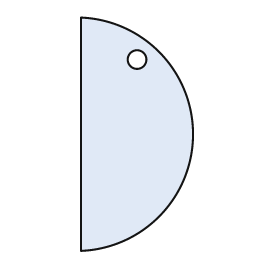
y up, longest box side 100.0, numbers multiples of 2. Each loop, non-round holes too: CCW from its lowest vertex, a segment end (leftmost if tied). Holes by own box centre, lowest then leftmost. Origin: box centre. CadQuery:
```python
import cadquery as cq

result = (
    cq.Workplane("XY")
    .moveTo(-24.0, -50.0)
    .threePointArc((24.0, 0.0), (-24.0, 50.0))
    .close()
    .moveTo(0.0, 32.0)
    .circle(4.0)
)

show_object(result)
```